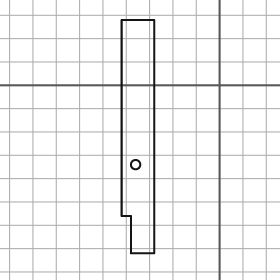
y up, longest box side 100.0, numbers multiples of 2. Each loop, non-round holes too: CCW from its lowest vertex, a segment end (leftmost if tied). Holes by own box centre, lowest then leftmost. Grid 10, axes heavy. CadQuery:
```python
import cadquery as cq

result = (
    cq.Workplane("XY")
    .moveTo(-38.0, -72.0)
    .lineTo(-28.0, -72.0)
    .lineTo(-28.0, 28.0)
    .lineTo(-42.0, 28.0)
    .lineTo(-42.0, -56.0)
    .lineTo(-38.0, -56.0)
    .close()
    .moveTo(-36.0, -34.0)
    .circle(2.0)
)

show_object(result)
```